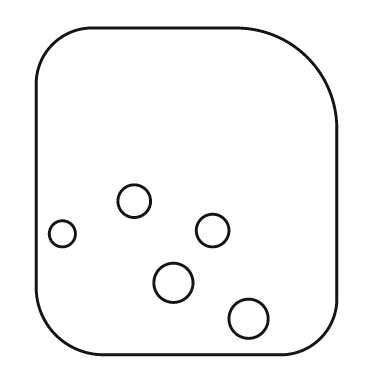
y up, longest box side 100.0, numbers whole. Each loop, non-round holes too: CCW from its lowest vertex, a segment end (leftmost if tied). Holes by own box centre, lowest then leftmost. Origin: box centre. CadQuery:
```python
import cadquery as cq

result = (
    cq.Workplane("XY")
    .moveTo(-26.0, -50.0)
    .lineTo(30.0, -50.0)
    .threePointArc((41.0, -45.0), (46.0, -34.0))
    .lineTo(46.0, 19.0)
    .threePointArc((37.0, 41.0), (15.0, 50.0))
    .lineTo(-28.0, 50.0)
    .threePointArc((-41.0, 45.0), (-46.0, 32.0))
    .lineTo(-46.0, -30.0)
    .threePointArc((-40.0, -44.0), (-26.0, -50.0))
    .close()
    .moveTo(19.0, -39.0)
    .circle(6.0)
    .moveTo(-4.0, -28.0)
    .circle(6.0)
    .moveTo(-38.0, -13.0)
    .circle(4.0)
    .moveTo(8.0, -12.0)
    .circle(5.0)
    .moveTo(-16.0, -3.0)
    .circle(5.0)
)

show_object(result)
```